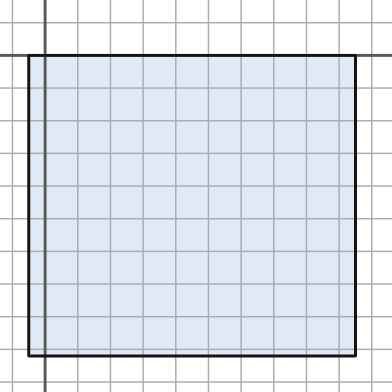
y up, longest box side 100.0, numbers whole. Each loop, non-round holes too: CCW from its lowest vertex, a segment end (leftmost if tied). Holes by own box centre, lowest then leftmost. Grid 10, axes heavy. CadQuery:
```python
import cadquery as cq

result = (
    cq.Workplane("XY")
    .moveTo(-5.0, -92.0)
    .lineTo(95.0, -92.0)
    .lineTo(95.0, 0.0)
    .lineTo(-5.0, 0.0)
    .close()
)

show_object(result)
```